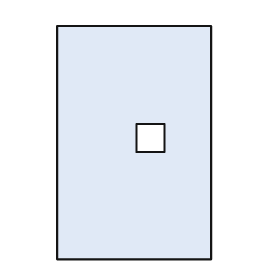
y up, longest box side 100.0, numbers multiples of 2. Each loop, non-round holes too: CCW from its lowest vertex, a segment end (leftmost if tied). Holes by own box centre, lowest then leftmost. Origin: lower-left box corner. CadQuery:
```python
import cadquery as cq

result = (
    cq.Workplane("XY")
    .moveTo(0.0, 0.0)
    .lineTo(66.0, 0.0)
    .lineTo(66.0, 100.0)
    .lineTo(0.0, 100.0)
    .close()
    .moveTo(34.0, 46.0)
    .lineTo(46.0, 46.0)
    .lineTo(46.0, 58.0)
    .lineTo(34.0, 58.0)
    .close()
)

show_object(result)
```